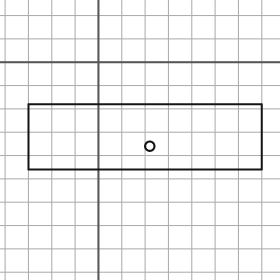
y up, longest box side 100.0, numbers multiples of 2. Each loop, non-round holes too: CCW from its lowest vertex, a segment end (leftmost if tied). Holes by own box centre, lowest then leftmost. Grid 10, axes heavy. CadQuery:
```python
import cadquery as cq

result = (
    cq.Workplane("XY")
    .moveTo(-30.0, -46.0)
    .lineTo(70.0, -46.0)
    .lineTo(70.0, -18.0)
    .lineTo(-30.0, -18.0)
    .close()
    .moveTo(22.0, -36.0)
    .circle(2.0)
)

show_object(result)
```